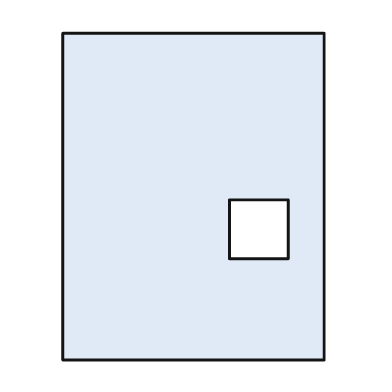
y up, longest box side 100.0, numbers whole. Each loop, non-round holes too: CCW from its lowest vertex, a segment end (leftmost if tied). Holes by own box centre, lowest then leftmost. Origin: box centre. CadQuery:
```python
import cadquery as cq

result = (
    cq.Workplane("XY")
    .moveTo(-40.0, -50.0)
    .lineTo(40.0, -50.0)
    .lineTo(40.0, 50.0)
    .lineTo(-40.0, 50.0)
    .close()
    .moveTo(11.0, -19.0)
    .lineTo(29.0, -19.0)
    .lineTo(29.0, -1.0)
    .lineTo(11.0, -1.0)
    .close()
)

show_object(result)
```